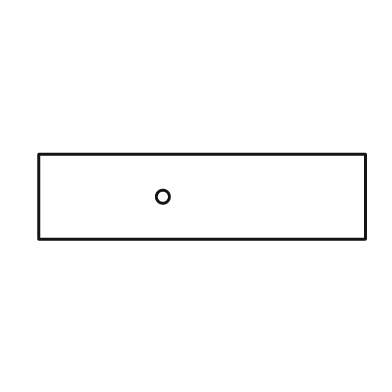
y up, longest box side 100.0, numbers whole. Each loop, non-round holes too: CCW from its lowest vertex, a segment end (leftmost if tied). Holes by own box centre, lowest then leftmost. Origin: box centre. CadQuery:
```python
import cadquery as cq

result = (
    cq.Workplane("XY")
    .moveTo(-50.0, -13.0)
    .lineTo(50.0, -13.0)
    .lineTo(50.0, 13.0)
    .lineTo(-50.0, 13.0)
    .close()
    .moveTo(-12.0, 0.0)
    .circle(2.0)
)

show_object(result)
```